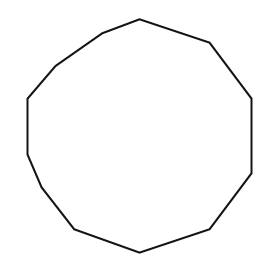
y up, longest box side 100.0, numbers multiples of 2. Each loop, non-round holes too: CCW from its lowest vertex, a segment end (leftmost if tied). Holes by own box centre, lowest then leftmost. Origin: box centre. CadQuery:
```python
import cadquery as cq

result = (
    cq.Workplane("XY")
    .moveTo(0.0, -50.0)
    .lineTo(30.0, -40.0)
    .lineTo(48.0, -16.0)
    .lineTo(48.0, 16.0)
    .lineTo(30.0, 40.0)
    .lineTo(0.0, 50.0)
    .lineTo(-16.0, 44.0)
    .lineTo(-36.0, 30.0)
    .lineTo(-48.0, 16.0)
    .lineTo(-48.0, -8.0)
    .lineTo(-42.0, -22.0)
    .lineTo(-28.0, -40.0)
    .close()
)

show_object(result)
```